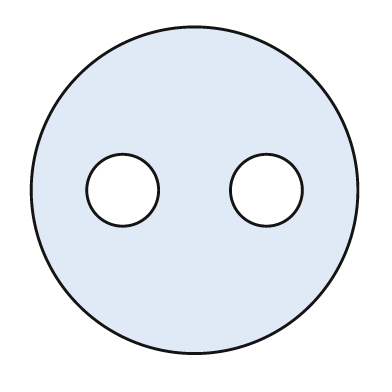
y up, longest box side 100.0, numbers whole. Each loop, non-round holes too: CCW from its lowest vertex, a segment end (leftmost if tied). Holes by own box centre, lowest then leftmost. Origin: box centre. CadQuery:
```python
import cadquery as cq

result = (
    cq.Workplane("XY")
    .moveTo(0.0, 0.0)
    .circle(50.0)
    .moveTo(-22.0, 0.0)
    .circle(11.0)
    .moveTo(22.0, 0.0)
    .circle(11.0)
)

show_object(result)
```